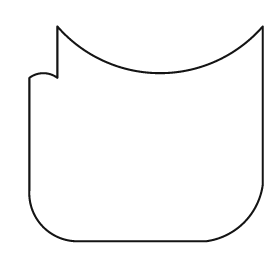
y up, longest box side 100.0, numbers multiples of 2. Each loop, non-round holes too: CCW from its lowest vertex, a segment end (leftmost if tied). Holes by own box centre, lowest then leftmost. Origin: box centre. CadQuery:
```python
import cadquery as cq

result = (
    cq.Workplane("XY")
    .moveTo(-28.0, -46.0)
    .lineTo(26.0, -46.0)
    .threePointArc((42.0, -38.0), (50.0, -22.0))
    .lineTo(50.0, 46.0)
    .threePointArc((6.0, 26.0), (-38.0, 46.0))
    .lineTo(-38.0, 24.0)
    .threePointArc((-44.0, 26.0), (-50.0, 24.0))
    .lineTo(-50.0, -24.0)
    .threePointArc((-44.0, -40.0), (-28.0, -46.0))
    .close()
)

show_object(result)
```